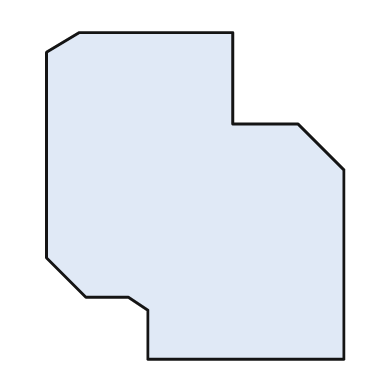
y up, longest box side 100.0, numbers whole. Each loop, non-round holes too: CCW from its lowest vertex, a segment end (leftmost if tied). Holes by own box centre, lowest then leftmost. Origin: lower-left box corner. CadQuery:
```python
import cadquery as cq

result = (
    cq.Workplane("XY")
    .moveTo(31.0, 0.0)
    .lineTo(91.0, 0.0)
    .lineTo(91.0, 58.0)
    .lineTo(77.0, 72.0)
    .lineTo(57.0, 72.0)
    .lineTo(57.0, 100.0)
    .lineTo(10.0, 100.0)
    .lineTo(0.0, 94.0)
    .lineTo(0.0, 31.0)
    .lineTo(12.0, 19.0)
    .lineTo(25.0, 19.0)
    .lineTo(31.0, 15.0)
    .close()
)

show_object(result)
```